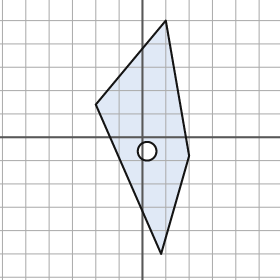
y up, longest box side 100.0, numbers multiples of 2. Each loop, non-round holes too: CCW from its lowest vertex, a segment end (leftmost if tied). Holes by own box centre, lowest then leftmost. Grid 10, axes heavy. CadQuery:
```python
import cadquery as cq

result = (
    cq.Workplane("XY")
    .moveTo(8.0, -50.0)
    .lineTo(20.0, -8.0)
    .lineTo(10.0, 50.0)
    .lineTo(-20.0, 14.0)
    .close()
    .moveTo(2.0, -6.0)
    .circle(4.0)
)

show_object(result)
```